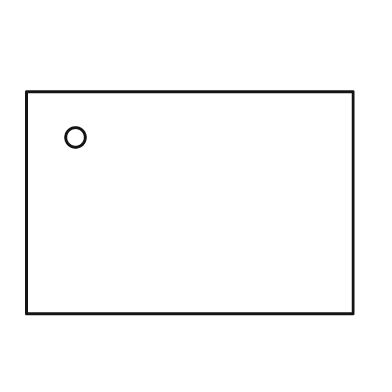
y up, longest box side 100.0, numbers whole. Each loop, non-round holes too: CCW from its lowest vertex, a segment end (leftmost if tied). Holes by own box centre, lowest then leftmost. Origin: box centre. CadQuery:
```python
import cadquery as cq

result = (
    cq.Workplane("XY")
    .moveTo(-50.0, -34.0)
    .lineTo(50.0, -34.0)
    .lineTo(50.0, 34.0)
    .lineTo(-50.0, 34.0)
    .close()
    .moveTo(-35.0, 20.0)
    .circle(3.0)
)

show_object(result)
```